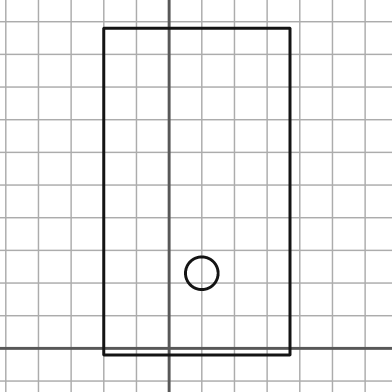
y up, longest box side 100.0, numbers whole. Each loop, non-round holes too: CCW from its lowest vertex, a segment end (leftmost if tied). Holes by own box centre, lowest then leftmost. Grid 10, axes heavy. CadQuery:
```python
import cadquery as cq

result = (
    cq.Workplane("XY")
    .moveTo(-20.0, -2.0)
    .lineTo(37.0, -2.0)
    .lineTo(37.0, 98.0)
    .lineTo(-20.0, 98.0)
    .close()
    .moveTo(10.0, 23.0)
    .circle(5.0)
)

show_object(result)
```